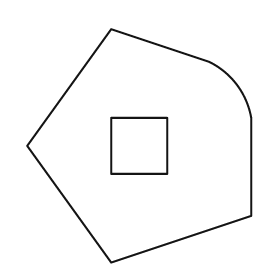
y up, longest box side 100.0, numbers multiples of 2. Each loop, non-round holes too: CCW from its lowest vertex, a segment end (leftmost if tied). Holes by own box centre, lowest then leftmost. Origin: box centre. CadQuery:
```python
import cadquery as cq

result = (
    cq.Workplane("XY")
    .moveTo(-12.0, -50.0)
    .lineTo(48.0, -30.0)
    .lineTo(48.0, 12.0)
    .threePointArc((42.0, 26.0), (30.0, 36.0))
    .lineTo(-12.0, 50.0)
    .lineTo(-48.0, 0.0)
    .close()
    .moveTo(-12.0, -12.0)
    .lineTo(12.0, -12.0)
    .lineTo(12.0, 12.0)
    .lineTo(-12.0, 12.0)
    .close()
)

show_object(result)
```